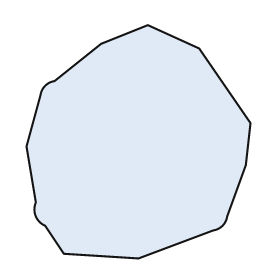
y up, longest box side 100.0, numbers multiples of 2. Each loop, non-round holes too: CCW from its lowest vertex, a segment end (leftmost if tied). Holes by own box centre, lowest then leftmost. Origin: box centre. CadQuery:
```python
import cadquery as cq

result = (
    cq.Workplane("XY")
    .moveTo(0.0, -50.0)
    .lineTo(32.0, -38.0)
    .threePointArc((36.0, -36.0), (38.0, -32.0))
    .lineTo(46.0, -10.0)
    .lineTo(48.0, 8.0)
    .lineTo(26.0, 40.0)
    .lineTo(4.0, 50.0)
    .lineTo(-16.0, 42.0)
    .lineTo(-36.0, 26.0)
    .threePointArc((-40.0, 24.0), (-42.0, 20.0))
    .lineTo(-48.0, -2.0)
    .lineTo(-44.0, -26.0)
    .threePointArc((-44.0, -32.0), (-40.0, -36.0))
    .lineTo(-32.0, -48.0)
    .close()
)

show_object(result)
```